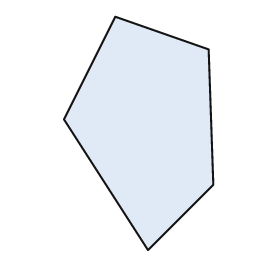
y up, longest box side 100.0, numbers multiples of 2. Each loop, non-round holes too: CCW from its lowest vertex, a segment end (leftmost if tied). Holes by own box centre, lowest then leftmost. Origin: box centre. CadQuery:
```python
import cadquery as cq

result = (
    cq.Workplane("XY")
    .moveTo(4.0, -50.0)
    .lineTo(32.0, -22.0)
    .lineTo(30.0, 36.0)
    .lineTo(-10.0, 50.0)
    .lineTo(-32.0, 6.0)
    .close()
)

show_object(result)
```